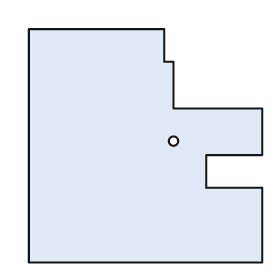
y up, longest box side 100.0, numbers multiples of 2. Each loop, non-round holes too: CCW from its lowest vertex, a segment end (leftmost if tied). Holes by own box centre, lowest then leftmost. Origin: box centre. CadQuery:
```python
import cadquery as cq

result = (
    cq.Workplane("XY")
    .moveTo(-50.0, -50.0)
    .lineTo(50.0, -50.0)
    .lineTo(50.0, -18.0)
    .lineTo(26.0, -18.0)
    .lineTo(26.0, -4.0)
    .lineTo(50.0, -4.0)
    .lineTo(50.0, 16.0)
    .lineTo(12.0, 16.0)
    .lineTo(12.0, 36.0)
    .lineTo(8.0, 36.0)
    .lineTo(8.0, 50.0)
    .lineTo(-50.0, 50.0)
    .close()
    .moveTo(12.0, 2.0)
    .circle(2.0)
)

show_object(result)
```